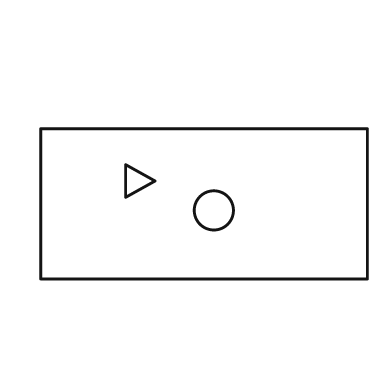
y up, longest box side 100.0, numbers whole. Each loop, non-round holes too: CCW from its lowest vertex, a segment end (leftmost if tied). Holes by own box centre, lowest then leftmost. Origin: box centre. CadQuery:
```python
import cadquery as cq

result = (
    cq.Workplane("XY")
    .moveTo(-50.0, -23.0)
    .lineTo(50.0, -23.0)
    .lineTo(50.0, 23.0)
    .lineTo(-50.0, 23.0)
    .close()
    .moveTo(3.0, -2.0)
    .circle(6.0)
    .moveTo(-24.0, 2.0)
    .lineTo(-15.0, 7.0)
    .lineTo(-24.0, 12.0)
    .close()
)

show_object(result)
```